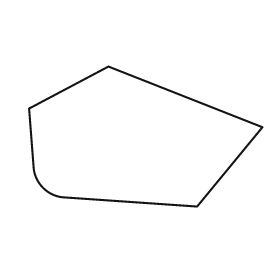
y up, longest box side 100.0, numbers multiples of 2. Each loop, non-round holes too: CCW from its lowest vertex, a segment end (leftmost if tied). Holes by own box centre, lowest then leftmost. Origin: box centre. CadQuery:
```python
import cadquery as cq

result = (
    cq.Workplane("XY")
    .moveTo(22.0, -30.0)
    .lineTo(50.0, 4.0)
    .lineTo(-16.0, 30.0)
    .lineTo(-50.0, 12.0)
    .lineTo(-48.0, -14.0)
    .threePointArc((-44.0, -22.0), (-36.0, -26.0))
    .close()
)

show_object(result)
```